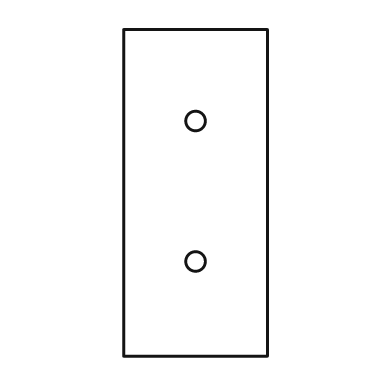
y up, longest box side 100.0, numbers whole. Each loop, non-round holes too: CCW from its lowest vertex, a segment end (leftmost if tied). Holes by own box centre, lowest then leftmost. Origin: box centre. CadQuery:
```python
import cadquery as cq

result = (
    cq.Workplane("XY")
    .moveTo(-22.0, -50.0)
    .lineTo(22.0, -50.0)
    .lineTo(22.0, 50.0)
    .lineTo(-22.0, 50.0)
    .close()
    .moveTo(0.0, -21.0)
    .circle(3.0)
    .moveTo(0.0, 22.0)
    .circle(3.0)
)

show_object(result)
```